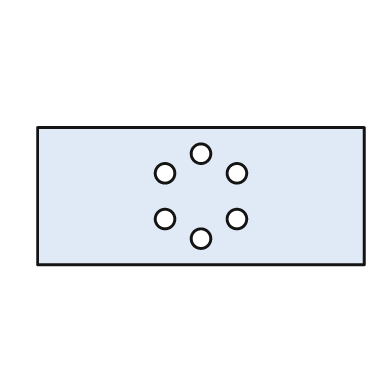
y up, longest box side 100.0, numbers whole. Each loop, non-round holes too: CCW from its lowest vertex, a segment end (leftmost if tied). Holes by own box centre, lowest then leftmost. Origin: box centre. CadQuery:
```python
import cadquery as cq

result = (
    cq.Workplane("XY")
    .moveTo(-50.0, -21.0)
    .lineTo(50.0, -21.0)
    .lineTo(50.0, 21.0)
    .lineTo(-50.0, 21.0)
    .close()
    .moveTo(0.0, -13.0)
    .circle(3.0)
    .moveTo(-11.0, -7.0)
    .circle(3.0)
    .moveTo(11.0, -7.0)
    .circle(3.0)
    .moveTo(-11.0, 7.0)
    .circle(3.0)
    .moveTo(11.0, 7.0)
    .circle(3.0)
    .moveTo(0.0, 13.0)
    .circle(3.0)
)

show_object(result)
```